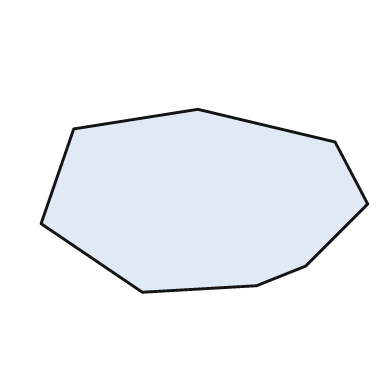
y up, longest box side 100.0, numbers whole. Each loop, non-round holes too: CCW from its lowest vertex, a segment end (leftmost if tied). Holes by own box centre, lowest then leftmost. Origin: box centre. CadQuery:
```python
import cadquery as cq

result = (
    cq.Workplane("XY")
    .moveTo(-19.0, -28.0)
    .lineTo(16.0, -26.0)
    .lineTo(31.0, -20.0)
    .lineTo(50.0, -1.0)
    .lineTo(40.0, 18.0)
    .lineTo(-2.0, 28.0)
    .lineTo(-40.0, 22.0)
    .lineTo(-50.0, -7.0)
    .close()
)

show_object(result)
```